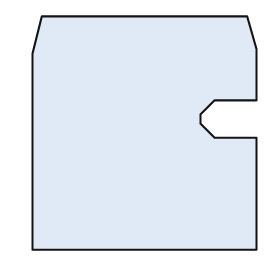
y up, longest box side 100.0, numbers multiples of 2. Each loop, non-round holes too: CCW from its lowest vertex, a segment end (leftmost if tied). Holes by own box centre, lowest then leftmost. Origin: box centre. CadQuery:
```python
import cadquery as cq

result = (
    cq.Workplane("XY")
    .moveTo(-48.0, -50.0)
    .lineTo(48.0, -50.0)
    .lineTo(48.0, -2.0)
    .lineTo(30.0, -2.0)
    .lineTo(24.0, 4.0)
    .lineTo(24.0, 8.0)
    .lineTo(30.0, 14.0)
    .lineTo(48.0, 14.0)
    .lineTo(48.0, 36.0)
    .lineTo(44.0, 50.0)
    .lineTo(-44.0, 50.0)
    .lineTo(-48.0, 34.0)
    .close()
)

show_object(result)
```